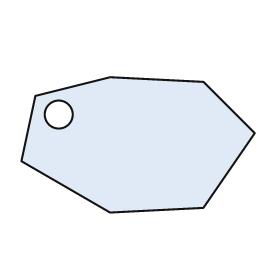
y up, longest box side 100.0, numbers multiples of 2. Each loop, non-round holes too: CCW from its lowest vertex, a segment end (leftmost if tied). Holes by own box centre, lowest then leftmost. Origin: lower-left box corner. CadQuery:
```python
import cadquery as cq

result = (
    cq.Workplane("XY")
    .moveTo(38.0, 0.0)
    .lineTo(78.0, 2.0)
    .lineTo(100.0, 34.0)
    .lineTo(78.0, 56.0)
    .lineTo(38.0, 58.0)
    .lineTo(6.0, 50.0)
    .lineTo(0.0, 22.0)
    .close()
    .moveTo(16.0, 42.0)
    .circle(6.0)
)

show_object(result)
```